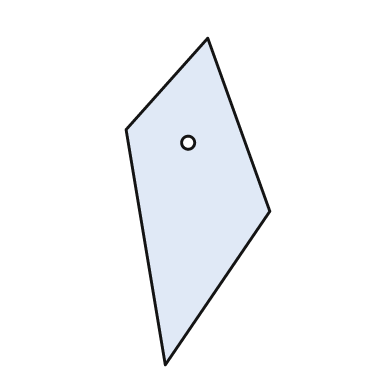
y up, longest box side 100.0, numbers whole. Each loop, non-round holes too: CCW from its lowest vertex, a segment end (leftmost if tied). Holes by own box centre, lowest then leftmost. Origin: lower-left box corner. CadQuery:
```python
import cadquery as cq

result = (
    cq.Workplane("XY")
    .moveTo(12.0, 0.0)
    .lineTo(44.0, 47.0)
    .lineTo(25.0, 100.0)
    .lineTo(0.0, 72.0)
    .close()
    .moveTo(19.0, 68.0)
    .circle(2.0)
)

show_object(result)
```